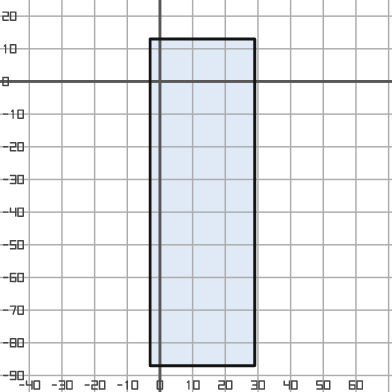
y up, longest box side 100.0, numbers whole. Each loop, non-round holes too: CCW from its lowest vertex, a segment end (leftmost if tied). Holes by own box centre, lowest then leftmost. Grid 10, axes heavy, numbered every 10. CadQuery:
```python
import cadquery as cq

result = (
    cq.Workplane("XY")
    .moveTo(-3.0, -87.0)
    .lineTo(29.0, -87.0)
    .lineTo(29.0, 13.0)
    .lineTo(-3.0, 13.0)
    .close()
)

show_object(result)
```